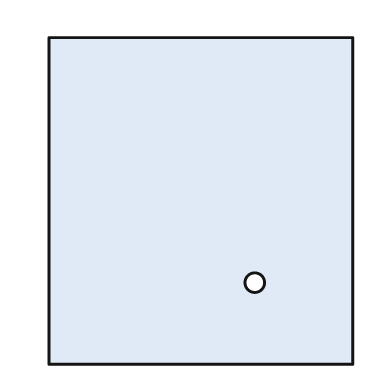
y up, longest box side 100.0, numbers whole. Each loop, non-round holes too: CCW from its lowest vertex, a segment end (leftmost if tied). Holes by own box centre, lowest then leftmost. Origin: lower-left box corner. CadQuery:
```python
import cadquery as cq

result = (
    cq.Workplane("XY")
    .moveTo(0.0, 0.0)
    .lineTo(93.0, 0.0)
    .lineTo(93.0, 100.0)
    .lineTo(0.0, 100.0)
    .close()
    .moveTo(63.0, 25.0)
    .circle(3.0)
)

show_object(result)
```